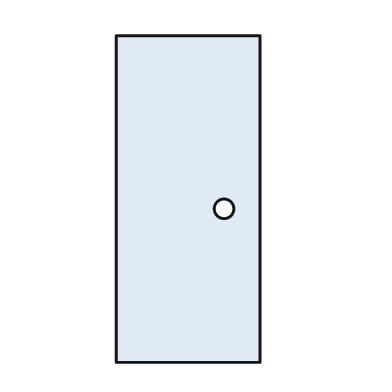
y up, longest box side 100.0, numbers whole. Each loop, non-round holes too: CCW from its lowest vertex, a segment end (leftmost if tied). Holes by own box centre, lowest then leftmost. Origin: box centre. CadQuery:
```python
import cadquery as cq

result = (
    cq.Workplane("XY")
    .moveTo(-22.0, -50.0)
    .lineTo(22.0, -50.0)
    .lineTo(22.0, 50.0)
    .lineTo(-22.0, 50.0)
    .close()
    .moveTo(11.0, -3.0)
    .circle(3.0)
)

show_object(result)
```